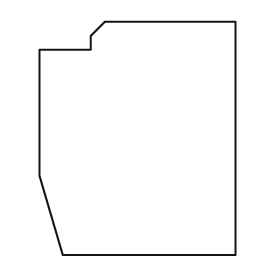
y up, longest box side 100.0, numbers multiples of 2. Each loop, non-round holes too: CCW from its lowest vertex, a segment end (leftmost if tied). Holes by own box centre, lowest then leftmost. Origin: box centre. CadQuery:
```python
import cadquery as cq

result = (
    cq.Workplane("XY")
    .moveTo(-32.0, -50.0)
    .lineTo(42.0, -50.0)
    .lineTo(42.0, 50.0)
    .lineTo(-14.0, 50.0)
    .lineTo(-20.0, 44.0)
    .lineTo(-20.0, 38.0)
    .lineTo(-42.0, 38.0)
    .lineTo(-42.0, -16.0)
    .close()
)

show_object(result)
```